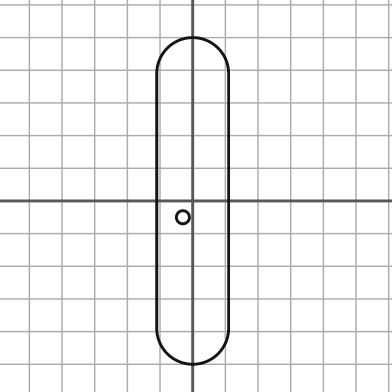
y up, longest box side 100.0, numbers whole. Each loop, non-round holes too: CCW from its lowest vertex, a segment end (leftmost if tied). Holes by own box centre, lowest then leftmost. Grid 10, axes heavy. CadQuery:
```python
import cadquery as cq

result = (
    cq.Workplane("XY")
    .moveTo(-11.0, -39.0)
    .threePointArc((0.0, -50.0), (11.0, -39.0))
    .lineTo(11.0, 39.0)
    .threePointArc((0.0, 50.0), (-11.0, 39.0))
    .close()
    .moveTo(-3.0, -5.0)
    .circle(2.0)
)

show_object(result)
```